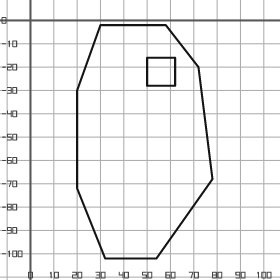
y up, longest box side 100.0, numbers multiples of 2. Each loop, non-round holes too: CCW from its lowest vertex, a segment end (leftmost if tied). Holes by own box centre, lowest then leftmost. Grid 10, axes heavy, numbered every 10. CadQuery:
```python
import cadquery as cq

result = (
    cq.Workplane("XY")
    .moveTo(32.0, -102.0)
    .lineTo(54.0, -102.0)
    .lineTo(78.0, -68.0)
    .lineTo(72.0, -20.0)
    .lineTo(58.0, -2.0)
    .lineTo(30.0, -2.0)
    .lineTo(20.0, -30.0)
    .lineTo(20.0, -72.0)
    .close()
    .moveTo(50.0, -28.0)
    .lineTo(62.0, -28.0)
    .lineTo(62.0, -16.0)
    .lineTo(50.0, -16.0)
    .close()
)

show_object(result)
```